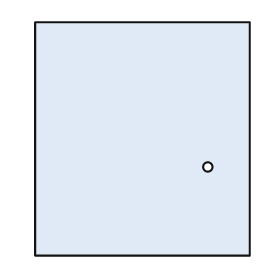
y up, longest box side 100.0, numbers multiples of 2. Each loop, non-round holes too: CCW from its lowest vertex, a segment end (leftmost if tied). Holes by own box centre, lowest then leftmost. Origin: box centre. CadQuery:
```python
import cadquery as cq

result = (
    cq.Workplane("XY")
    .moveTo(-46.0, -50.0)
    .lineTo(46.0, -50.0)
    .lineTo(46.0, 50.0)
    .lineTo(-46.0, 50.0)
    .close()
    .moveTo(28.0, -12.0)
    .circle(2.0)
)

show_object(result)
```